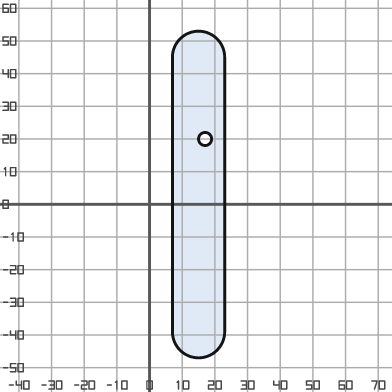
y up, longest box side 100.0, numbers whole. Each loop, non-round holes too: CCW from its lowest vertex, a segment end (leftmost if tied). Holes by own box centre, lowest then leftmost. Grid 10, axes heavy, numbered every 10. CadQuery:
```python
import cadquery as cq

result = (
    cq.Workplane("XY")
    .moveTo(7.0, -39.0)
    .threePointArc((15.0, -47.0), (23.0, -39.0))
    .lineTo(23.0, 45.0)
    .threePointArc((15.0, 53.0), (7.0, 45.0))
    .close()
    .moveTo(17.0, 20.0)
    .circle(2.0)
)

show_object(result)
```